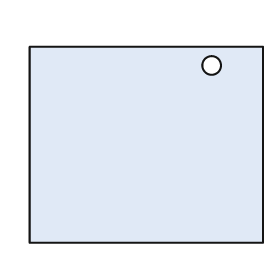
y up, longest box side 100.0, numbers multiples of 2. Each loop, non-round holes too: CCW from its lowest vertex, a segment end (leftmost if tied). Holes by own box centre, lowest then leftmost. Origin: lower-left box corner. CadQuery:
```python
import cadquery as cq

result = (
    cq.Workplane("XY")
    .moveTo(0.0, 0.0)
    .lineTo(100.0, 0.0)
    .lineTo(100.0, 84.0)
    .lineTo(0.0, 84.0)
    .close()
    .moveTo(78.0, 76.0)
    .circle(4.0)
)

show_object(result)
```